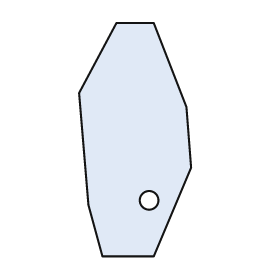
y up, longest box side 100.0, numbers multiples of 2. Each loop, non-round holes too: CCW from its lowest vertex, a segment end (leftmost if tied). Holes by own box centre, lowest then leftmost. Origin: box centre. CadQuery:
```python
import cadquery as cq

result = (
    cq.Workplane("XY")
    .moveTo(-14.0, -50.0)
    .lineTo(8.0, -50.0)
    .lineTo(24.0, -12.0)
    .lineTo(22.0, 14.0)
    .lineTo(8.0, 50.0)
    .lineTo(-8.0, 50.0)
    .lineTo(-24.0, 20.0)
    .lineTo(-20.0, -28.0)
    .close()
    .moveTo(6.0, -26.0)
    .circle(4.0)
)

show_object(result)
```